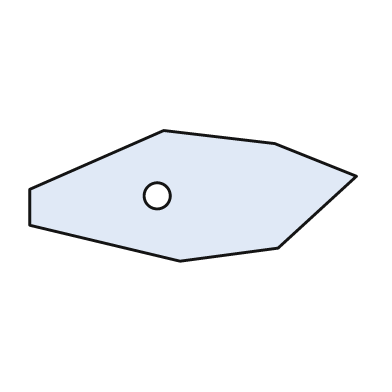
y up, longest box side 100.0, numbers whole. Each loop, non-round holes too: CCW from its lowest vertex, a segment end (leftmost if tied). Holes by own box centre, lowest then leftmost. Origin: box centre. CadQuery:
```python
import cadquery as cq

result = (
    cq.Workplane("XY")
    .moveTo(-4.0, -20.0)
    .lineTo(26.0, -16.0)
    .lineTo(50.0, 6.0)
    .lineTo(25.0, 16.0)
    .lineTo(-9.0, 20.0)
    .lineTo(-50.0, 2.0)
    .lineTo(-50.0, -9.0)
    .close()
    .moveTo(-11.0, 0.0)
    .circle(4.0)
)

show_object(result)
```